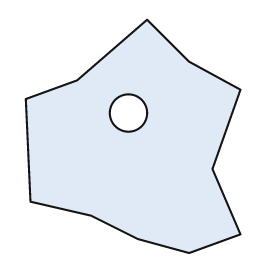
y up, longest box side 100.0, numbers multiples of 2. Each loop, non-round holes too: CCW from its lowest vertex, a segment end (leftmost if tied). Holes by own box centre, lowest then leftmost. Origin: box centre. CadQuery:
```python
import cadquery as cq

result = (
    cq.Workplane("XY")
    .moveTo(24.0, -50.0)
    .lineTo(46.0, -42.0)
    .lineTo(34.0, -14.0)
    .lineTo(46.0, 20.0)
    .lineTo(24.0, 32.0)
    .lineTo(6.0, 50.0)
    .lineTo(-24.0, 24.0)
    .lineTo(-46.0, 16.0)
    .lineTo(-44.0, -28.0)
    .lineTo(-18.0, -34.0)
    .lineTo(2.0, -44.0)
    .close()
    .moveTo(-2.0, 10.0)
    .circle(8.0)
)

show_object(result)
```